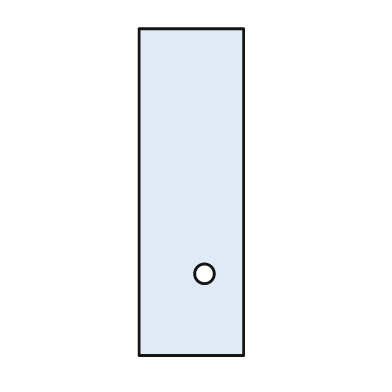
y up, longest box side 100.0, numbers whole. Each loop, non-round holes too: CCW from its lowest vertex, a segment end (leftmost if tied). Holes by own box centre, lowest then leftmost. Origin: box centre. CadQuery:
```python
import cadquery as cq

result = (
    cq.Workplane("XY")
    .moveTo(-16.0, -50.0)
    .lineTo(16.0, -50.0)
    .lineTo(16.0, 50.0)
    .lineTo(-16.0, 50.0)
    .close()
    .moveTo(4.0, -25.0)
    .circle(3.0)
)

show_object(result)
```